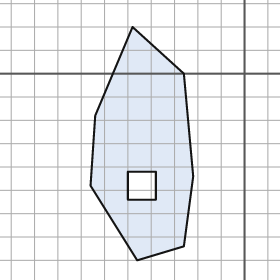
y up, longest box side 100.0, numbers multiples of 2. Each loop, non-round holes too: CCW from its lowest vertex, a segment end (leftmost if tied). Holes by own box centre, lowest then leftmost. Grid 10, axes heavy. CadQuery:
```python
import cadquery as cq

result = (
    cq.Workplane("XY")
    .moveTo(-46.0, -80.0)
    .lineTo(-26.0, -74.0)
    .lineTo(-22.0, -44.0)
    .lineTo(-26.0, 0.0)
    .lineTo(-48.0, 20.0)
    .lineTo(-64.0, -18.0)
    .lineTo(-66.0, -48.0)
    .close()
    .moveTo(-50.0, -54.0)
    .lineTo(-38.0, -54.0)
    .lineTo(-38.0, -42.0)
    .lineTo(-50.0, -42.0)
    .close()
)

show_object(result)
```